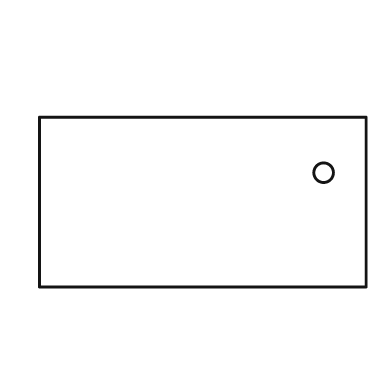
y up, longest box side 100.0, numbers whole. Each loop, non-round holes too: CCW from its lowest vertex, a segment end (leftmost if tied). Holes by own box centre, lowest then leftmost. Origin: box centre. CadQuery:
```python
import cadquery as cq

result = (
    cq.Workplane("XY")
    .moveTo(-50.0, -26.0)
    .lineTo(50.0, -26.0)
    .lineTo(50.0, 26.0)
    .lineTo(-50.0, 26.0)
    .close()
    .moveTo(37.0, 9.0)
    .circle(3.0)
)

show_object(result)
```